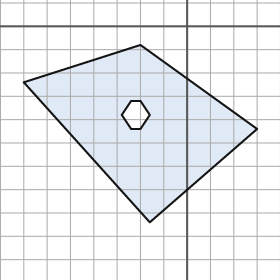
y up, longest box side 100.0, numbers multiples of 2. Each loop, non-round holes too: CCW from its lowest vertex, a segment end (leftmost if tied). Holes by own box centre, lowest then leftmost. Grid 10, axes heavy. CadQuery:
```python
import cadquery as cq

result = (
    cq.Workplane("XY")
    .moveTo(-16.0, -84.0)
    .lineTo(30.0, -44.0)
    .lineTo(-20.0, -8.0)
    .lineTo(-70.0, -24.0)
    .close()
    .moveTo(-24.0, -44.0)
    .lineTo(-20.0, -44.0)
    .lineTo(-16.0, -38.0)
    .lineTo(-20.0, -32.0)
    .lineTo(-24.0, -32.0)
    .lineTo(-28.0, -38.0)
    .close()
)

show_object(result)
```